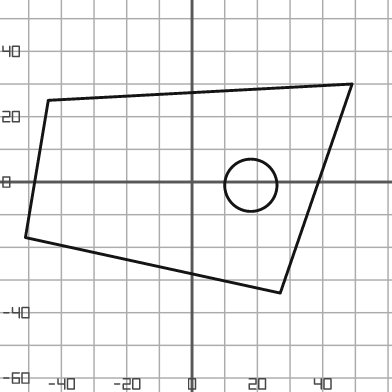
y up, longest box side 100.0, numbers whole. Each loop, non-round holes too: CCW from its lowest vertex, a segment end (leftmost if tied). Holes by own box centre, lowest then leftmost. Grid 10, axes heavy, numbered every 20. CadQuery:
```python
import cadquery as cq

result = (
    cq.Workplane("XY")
    .moveTo(27.0, -34.0)
    .lineTo(49.0, 30.0)
    .lineTo(-44.0, 25.0)
    .lineTo(-51.0, -17.0)
    .close()
    .moveTo(18.0, -1.0)
    .circle(8.0)
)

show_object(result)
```